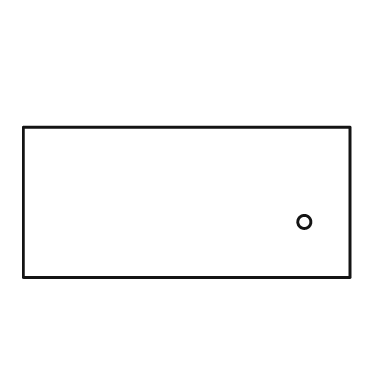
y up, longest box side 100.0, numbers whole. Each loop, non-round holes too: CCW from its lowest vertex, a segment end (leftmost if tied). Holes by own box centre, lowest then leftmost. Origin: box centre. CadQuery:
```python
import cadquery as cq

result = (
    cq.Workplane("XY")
    .moveTo(-50.0, -23.0)
    .lineTo(50.0, -23.0)
    .lineTo(50.0, 23.0)
    .lineTo(-50.0, 23.0)
    .close()
    .moveTo(36.0, -6.0)
    .circle(2.0)
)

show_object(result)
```